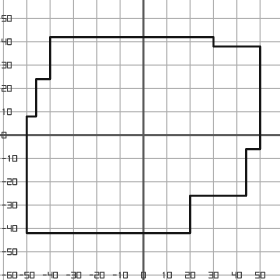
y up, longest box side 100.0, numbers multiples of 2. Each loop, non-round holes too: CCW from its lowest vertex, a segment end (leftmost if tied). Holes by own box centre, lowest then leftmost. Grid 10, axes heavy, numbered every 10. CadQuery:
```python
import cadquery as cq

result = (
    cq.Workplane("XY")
    .moveTo(-50.0, -42.0)
    .lineTo(20.0, -42.0)
    .lineTo(20.0, -26.0)
    .lineTo(44.0, -26.0)
    .lineTo(44.0, -6.0)
    .lineTo(50.0, -6.0)
    .lineTo(50.0, 38.0)
    .lineTo(30.0, 38.0)
    .lineTo(30.0, 42.0)
    .lineTo(-40.0, 42.0)
    .lineTo(-40.0, 24.0)
    .lineTo(-46.0, 24.0)
    .lineTo(-46.0, 8.0)
    .lineTo(-50.0, 8.0)
    .close()
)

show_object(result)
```